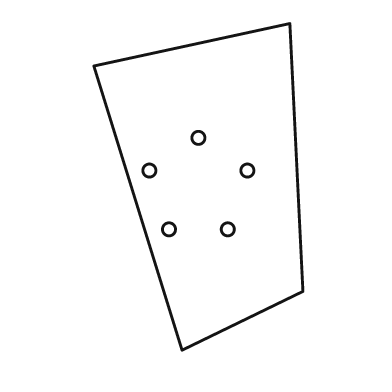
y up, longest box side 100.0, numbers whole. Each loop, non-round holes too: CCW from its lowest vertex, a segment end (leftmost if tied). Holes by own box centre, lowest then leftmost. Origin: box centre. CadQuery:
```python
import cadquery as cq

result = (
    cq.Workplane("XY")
    .moveTo(-5.0, -50.0)
    .lineTo(32.0, -32.0)
    .lineTo(28.0, 50.0)
    .lineTo(-32.0, 37.0)
    .close()
    .moveTo(-9.0, -13.0)
    .circle(2.0)
    .moveTo(9.0, -13.0)
    .circle(2.0)
    .moveTo(-15.0, 5.0)
    .circle(2.0)
    .moveTo(15.0, 5.0)
    .circle(2.0)
    .moveTo(0.0, 15.0)
    .circle(2.0)
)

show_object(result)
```